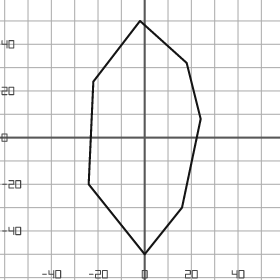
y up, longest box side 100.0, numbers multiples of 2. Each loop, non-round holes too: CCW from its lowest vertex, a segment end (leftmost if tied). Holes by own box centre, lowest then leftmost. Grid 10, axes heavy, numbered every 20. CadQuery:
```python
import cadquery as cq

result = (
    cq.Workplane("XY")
    .moveTo(0.0, -50.0)
    .lineTo(16.0, -30.0)
    .lineTo(24.0, 8.0)
    .lineTo(18.0, 32.0)
    .lineTo(-2.0, 50.0)
    .lineTo(-22.0, 24.0)
    .lineTo(-24.0, -20.0)
    .close()
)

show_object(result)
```